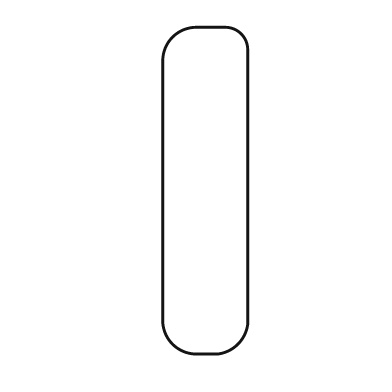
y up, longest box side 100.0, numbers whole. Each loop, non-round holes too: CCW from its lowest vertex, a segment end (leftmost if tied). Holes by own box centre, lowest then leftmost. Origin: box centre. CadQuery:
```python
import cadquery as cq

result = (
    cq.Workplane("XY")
    .moveTo(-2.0, -50.0)
    .lineTo(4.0, -50.0)
    .threePointArc((10.0, -47.0), (13.0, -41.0))
    .lineTo(13.0, 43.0)
    .threePointArc((11.0, 48.0), (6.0, 50.0))
    .lineTo(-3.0, 50.0)
    .threePointArc((-10.0, 47.0), (-13.0, 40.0))
    .lineTo(-13.0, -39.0)
    .threePointArc((-10.0, -47.0), (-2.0, -50.0))
    .close()
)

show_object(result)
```